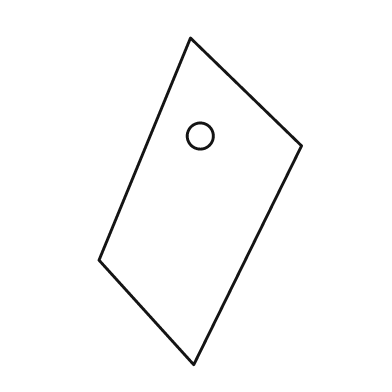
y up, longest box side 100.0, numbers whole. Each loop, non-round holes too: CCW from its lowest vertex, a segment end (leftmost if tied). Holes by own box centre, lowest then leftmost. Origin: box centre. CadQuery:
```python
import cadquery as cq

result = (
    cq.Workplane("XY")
    .moveTo(-2.0, -50.0)
    .lineTo(31.0, 17.0)
    .lineTo(-3.0, 50.0)
    .lineTo(-31.0, -18.0)
    .close()
    .moveTo(0.0, 20.0)
    .circle(4.0)
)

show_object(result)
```